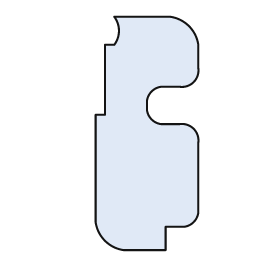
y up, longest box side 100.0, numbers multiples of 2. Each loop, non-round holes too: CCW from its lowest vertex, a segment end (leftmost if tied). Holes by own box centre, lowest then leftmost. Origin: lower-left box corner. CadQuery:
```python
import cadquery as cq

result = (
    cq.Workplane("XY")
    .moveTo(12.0, 0.0)
    .lineTo(30.0, 0.0)
    .lineTo(30.0, 10.0)
    .lineTo(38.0, 10.0)
    .threePointArc((42.0, 12.0), (44.0, 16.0))
    .lineTo(44.0, 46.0)
    .threePointArc((42.0, 52.0), (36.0, 54.0))
    .lineTo(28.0, 54.0)
    .threePointArc((24.0, 56.0), (22.0, 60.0))
    .lineTo(22.0, 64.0)
    .threePointArc((24.0, 68.0), (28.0, 70.0))
    .lineTo(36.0, 70.0)
    .threePointArc((42.0, 72.0), (44.0, 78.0))
    .lineTo(44.0, 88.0)
    .threePointArc((40.0, 96.0), (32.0, 100.0))
    .lineTo(8.0, 100.0)
    .threePointArc((10.0, 94.0), (8.0, 88.0))
    .lineTo(4.0, 88.0)
    .lineTo(4.0, 58.0)
    .lineTo(0.0, 58.0)
    .lineTo(0.0, 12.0)
    .threePointArc((4.0, 4.0), (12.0, 0.0))
    .close()
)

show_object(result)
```